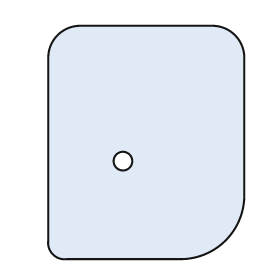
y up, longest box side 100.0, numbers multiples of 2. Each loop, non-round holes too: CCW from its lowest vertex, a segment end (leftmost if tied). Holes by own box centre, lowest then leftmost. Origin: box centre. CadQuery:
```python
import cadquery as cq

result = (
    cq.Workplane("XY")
    .moveTo(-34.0, -50.0)
    .lineTo(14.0, -50.0)
    .threePointArc((34.0, -42.0), (42.0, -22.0))
    .lineTo(42.0, 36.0)
    .threePointArc((38.0, 46.0), (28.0, 50.0))
    .lineTo(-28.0, 50.0)
    .threePointArc((-38.0, 46.0), (-42.0, 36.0))
    .lineTo(-42.0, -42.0)
    .threePointArc((-40.0, -48.0), (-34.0, -50.0))
    .close()
    .moveTo(-10.0, -8.0)
    .circle(4.0)
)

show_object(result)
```